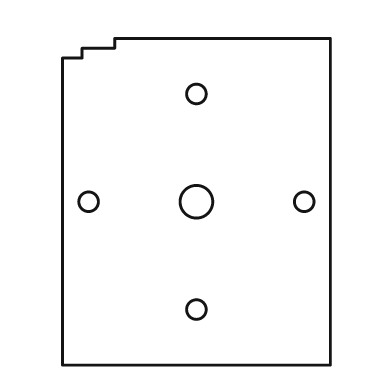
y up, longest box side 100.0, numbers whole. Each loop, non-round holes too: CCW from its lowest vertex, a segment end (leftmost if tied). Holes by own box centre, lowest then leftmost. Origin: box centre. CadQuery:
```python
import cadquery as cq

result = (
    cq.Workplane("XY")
    .moveTo(-41.0, -50.0)
    .lineTo(41.0, -50.0)
    .lineTo(41.0, 50.0)
    .lineTo(-25.0, 50.0)
    .lineTo(-25.0, 47.0)
    .lineTo(-35.0, 47.0)
    .lineTo(-35.0, 44.0)
    .lineTo(-41.0, 44.0)
    .close()
    .moveTo(0.0, -33.0)
    .circle(3.0)
    .moveTo(-33.0, 0.0)
    .circle(3.0)
    .moveTo(0.0, 0.0)
    .circle(5.0)
    .moveTo(33.0, 0.0)
    .circle(3.0)
    .moveTo(0.0, 33.0)
    .circle(3.0)
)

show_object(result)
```